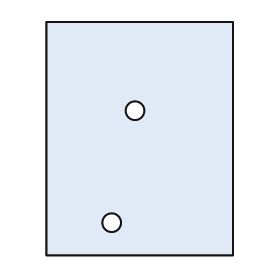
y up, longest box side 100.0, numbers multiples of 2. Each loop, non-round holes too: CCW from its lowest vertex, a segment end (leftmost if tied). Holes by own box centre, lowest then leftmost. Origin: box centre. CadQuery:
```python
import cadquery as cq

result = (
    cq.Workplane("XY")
    .moveTo(-40.0, -50.0)
    .lineTo(40.0, -50.0)
    .lineTo(40.0, 50.0)
    .lineTo(-40.0, 50.0)
    .close()
    .moveTo(-12.0, -36.0)
    .circle(4.0)
    .moveTo(-2.0, 12.0)
    .circle(4.0)
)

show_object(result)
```